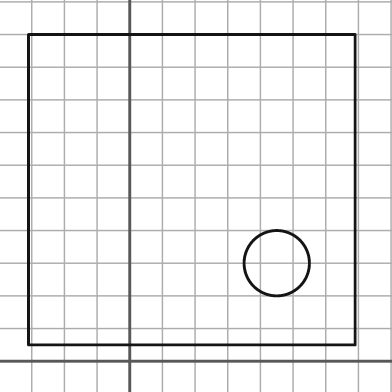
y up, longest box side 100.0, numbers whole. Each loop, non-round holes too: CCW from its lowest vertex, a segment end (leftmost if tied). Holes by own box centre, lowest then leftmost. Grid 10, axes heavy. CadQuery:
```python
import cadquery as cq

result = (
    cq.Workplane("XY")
    .moveTo(-31.0, 5.0)
    .lineTo(69.0, 5.0)
    .lineTo(69.0, 100.0)
    .lineTo(-31.0, 100.0)
    .close()
    .moveTo(45.0, 30.0)
    .circle(10.0)
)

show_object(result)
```